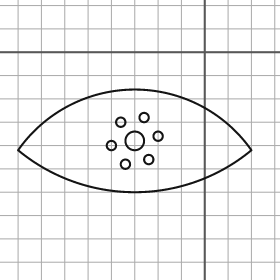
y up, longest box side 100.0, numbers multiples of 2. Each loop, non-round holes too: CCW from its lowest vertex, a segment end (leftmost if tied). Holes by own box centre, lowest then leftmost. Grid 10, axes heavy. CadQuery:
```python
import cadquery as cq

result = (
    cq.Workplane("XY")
    .moveTo(-80.0, -42.0)
    .threePointArc((-30.0, -60.0), (20.0, -42.0))
    .threePointArc((-30.0, -16.0), (-80.0, -42.0))
    .close()
    .moveTo(-34.0, -48.0)
    .circle(2.0)
    .moveTo(-24.0, -46.0)
    .circle(2.0)
    .moveTo(-40.0, -40.0)
    .circle(2.0)
    .moveTo(-30.0, -38.0)
    .circle(4.0)
    .moveTo(-20.0, -36.0)
    .circle(2.0)
    .moveTo(-36.0, -30.0)
    .circle(2.0)
    .moveTo(-26.0, -28.0)
    .circle(2.0)
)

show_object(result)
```